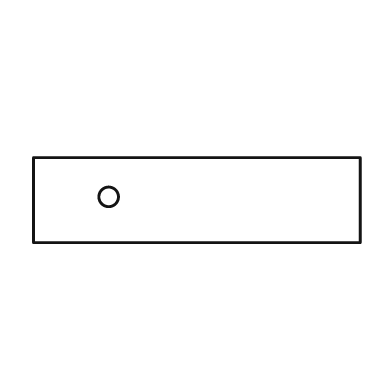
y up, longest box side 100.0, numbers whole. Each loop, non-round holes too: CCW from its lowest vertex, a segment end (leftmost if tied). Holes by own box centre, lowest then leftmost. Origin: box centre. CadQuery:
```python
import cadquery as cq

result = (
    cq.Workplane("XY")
    .moveTo(-50.0, -13.0)
    .lineTo(50.0, -13.0)
    .lineTo(50.0, 13.0)
    .lineTo(-50.0, 13.0)
    .close()
    .moveTo(-27.0, 1.0)
    .circle(3.0)
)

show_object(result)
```